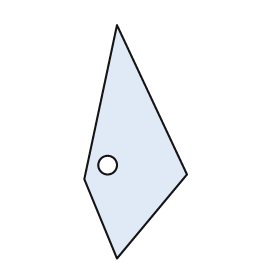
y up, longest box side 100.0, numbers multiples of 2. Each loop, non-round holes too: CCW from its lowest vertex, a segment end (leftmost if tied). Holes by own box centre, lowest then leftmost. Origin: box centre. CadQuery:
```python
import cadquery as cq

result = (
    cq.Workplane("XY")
    .moveTo(-8.0, -50.0)
    .lineTo(22.0, -14.0)
    .lineTo(-8.0, 50.0)
    .lineTo(-22.0, -16.0)
    .close()
    .moveTo(-12.0, -10.0)
    .circle(4.0)
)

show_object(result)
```